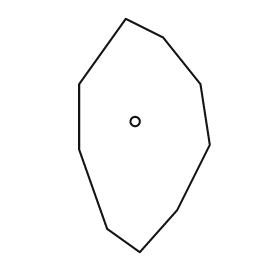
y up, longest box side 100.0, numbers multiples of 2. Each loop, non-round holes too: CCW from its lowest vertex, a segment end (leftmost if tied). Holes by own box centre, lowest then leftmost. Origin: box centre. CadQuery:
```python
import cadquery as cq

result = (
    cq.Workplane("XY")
    .moveTo(-2.0, -50.0)
    .lineTo(14.0, -32.0)
    .lineTo(28.0, -4.0)
    .lineTo(24.0, 22.0)
    .lineTo(8.0, 42.0)
    .lineTo(-8.0, 50.0)
    .lineTo(-28.0, 22.0)
    .lineTo(-28.0, -6.0)
    .lineTo(-16.0, -40.0)
    .close()
    .moveTo(-4.0, 6.0)
    .circle(2.0)
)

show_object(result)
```